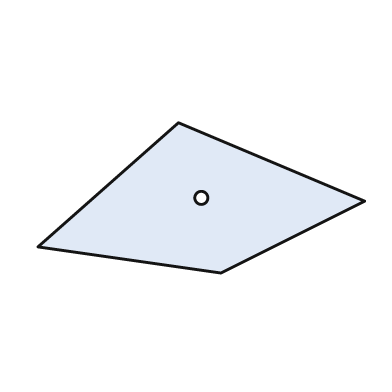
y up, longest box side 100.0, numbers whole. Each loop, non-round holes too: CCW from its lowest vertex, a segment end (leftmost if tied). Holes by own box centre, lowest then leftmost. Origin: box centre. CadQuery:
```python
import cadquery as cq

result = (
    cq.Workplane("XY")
    .moveTo(6.0, -23.0)
    .lineTo(50.0, -1.0)
    .lineTo(-7.0, 23.0)
    .lineTo(-50.0, -15.0)
    .close()
    .moveTo(0.0, 0.0)
    .circle(2.0)
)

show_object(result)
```